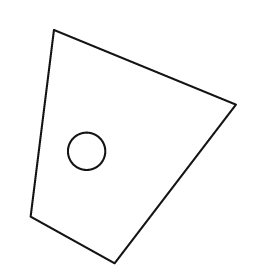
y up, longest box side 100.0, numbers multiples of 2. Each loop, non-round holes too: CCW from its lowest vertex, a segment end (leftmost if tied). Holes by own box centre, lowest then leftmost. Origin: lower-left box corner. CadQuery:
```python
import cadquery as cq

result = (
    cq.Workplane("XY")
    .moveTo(36.0, 0.0)
    .lineTo(88.0, 68.0)
    .lineTo(10.0, 100.0)
    .lineTo(0.0, 20.0)
    .close()
    .moveTo(24.0, 48.0)
    .circle(8.0)
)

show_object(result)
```